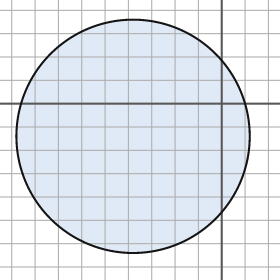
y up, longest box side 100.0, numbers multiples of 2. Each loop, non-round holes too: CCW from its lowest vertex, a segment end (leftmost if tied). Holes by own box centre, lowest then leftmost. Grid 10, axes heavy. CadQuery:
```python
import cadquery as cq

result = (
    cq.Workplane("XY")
    .moveTo(-38.0, -14.0)
    .circle(50.0)
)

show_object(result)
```